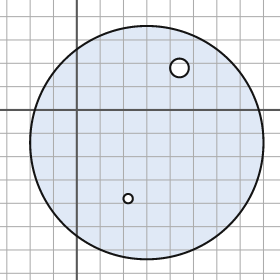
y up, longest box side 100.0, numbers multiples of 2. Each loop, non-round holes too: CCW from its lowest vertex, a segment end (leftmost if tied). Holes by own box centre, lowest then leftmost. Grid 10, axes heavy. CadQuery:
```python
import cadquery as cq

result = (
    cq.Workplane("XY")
    .moveTo(30.0, -14.0)
    .circle(50.0)
    .moveTo(22.0, -38.0)
    .circle(2.0)
    .moveTo(44.0, 18.0)
    .circle(4.0)
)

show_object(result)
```